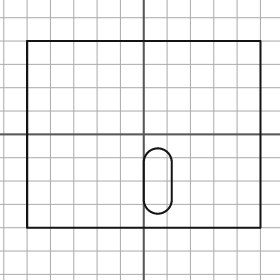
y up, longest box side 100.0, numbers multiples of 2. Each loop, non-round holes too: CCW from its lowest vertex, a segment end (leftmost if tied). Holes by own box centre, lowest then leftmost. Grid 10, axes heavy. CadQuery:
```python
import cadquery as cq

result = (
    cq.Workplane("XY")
    .moveTo(-50.0, -40.0)
    .lineTo(50.0, -40.0)
    .lineTo(50.0, 40.0)
    .lineTo(-50.0, 40.0)
    .close()
    .moveTo(0.0, -28.0)
    .threePointArc((6.0, -34.0), (12.0, -28.0))
    .lineTo(12.0, -12.0)
    .threePointArc((6.0, -6.0), (0.0, -12.0))
    .close()
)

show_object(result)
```